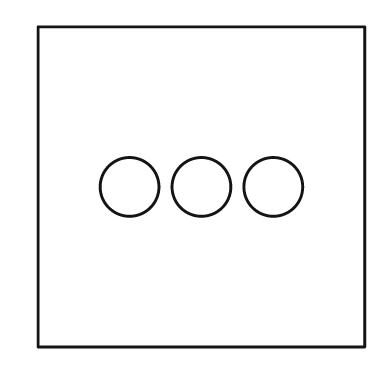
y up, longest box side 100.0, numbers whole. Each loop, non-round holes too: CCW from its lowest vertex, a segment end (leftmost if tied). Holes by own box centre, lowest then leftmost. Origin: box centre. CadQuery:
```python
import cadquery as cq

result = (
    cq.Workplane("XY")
    .moveTo(-50.0, -49.0)
    .lineTo(50.0, -49.0)
    .lineTo(50.0, 49.0)
    .lineTo(-50.0, 49.0)
    .close()
    .moveTo(-22.0, 0.0)
    .circle(9.0)
    .moveTo(0.0, 0.0)
    .circle(9.0)
    .moveTo(22.0, 0.0)
    .circle(9.0)
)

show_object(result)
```